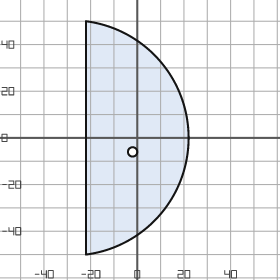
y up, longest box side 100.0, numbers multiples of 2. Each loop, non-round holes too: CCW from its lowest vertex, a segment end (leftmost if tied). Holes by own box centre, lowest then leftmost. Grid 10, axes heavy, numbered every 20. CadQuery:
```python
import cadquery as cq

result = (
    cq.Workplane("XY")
    .moveTo(-22.0, -50.0)
    .threePointArc((22.0, 0.0), (-22.0, 50.0))
    .close()
    .moveTo(-2.0, -6.0)
    .circle(2.0)
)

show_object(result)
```